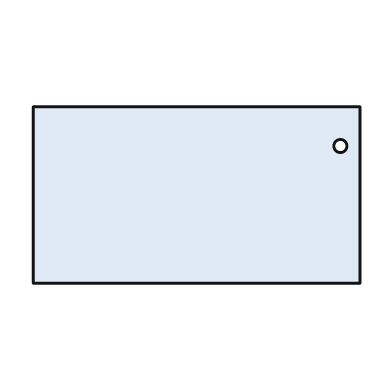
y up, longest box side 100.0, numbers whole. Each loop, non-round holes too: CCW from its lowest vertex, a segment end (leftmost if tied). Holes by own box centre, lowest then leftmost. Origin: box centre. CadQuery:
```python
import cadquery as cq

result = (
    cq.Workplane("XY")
    .moveTo(-50.0, -27.0)
    .lineTo(50.0, -27.0)
    .lineTo(50.0, 27.0)
    .lineTo(-50.0, 27.0)
    .close()
    .moveTo(44.0, 15.0)
    .circle(2.0)
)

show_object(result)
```